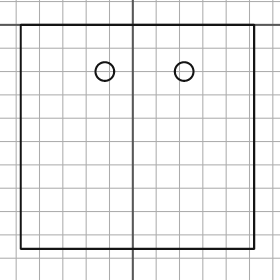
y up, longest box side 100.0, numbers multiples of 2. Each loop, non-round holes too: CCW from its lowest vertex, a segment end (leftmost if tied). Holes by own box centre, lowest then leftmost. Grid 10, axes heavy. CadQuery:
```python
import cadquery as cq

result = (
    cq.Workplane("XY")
    .moveTo(-48.0, -96.0)
    .lineTo(52.0, -96.0)
    .lineTo(52.0, 0.0)
    .lineTo(-48.0, 0.0)
    .close()
    .moveTo(-12.0, -20.0)
    .circle(4.0)
    .moveTo(22.0, -20.0)
    .circle(4.0)
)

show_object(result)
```